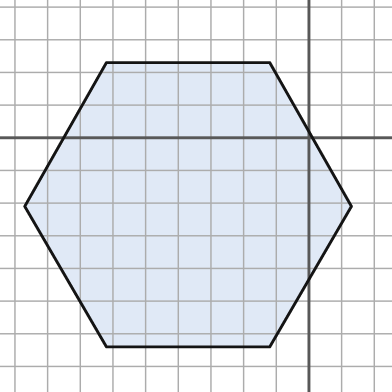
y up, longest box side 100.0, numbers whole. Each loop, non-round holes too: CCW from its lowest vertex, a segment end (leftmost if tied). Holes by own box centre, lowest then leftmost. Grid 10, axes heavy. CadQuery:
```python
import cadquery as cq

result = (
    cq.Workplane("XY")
    .moveTo(-62.0, -64.0)
    .lineTo(-12.0, -64.0)
    .lineTo(13.0, -21.0)
    .lineTo(-12.0, 23.0)
    .lineTo(-62.0, 23.0)
    .lineTo(-87.0, -21.0)
    .close()
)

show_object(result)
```